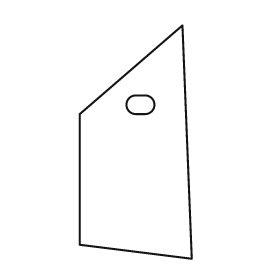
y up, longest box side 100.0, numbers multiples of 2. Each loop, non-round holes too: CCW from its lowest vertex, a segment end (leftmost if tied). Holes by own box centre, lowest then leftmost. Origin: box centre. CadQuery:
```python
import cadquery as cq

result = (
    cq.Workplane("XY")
    .moveTo(24.0, -50.0)
    .lineTo(20.0, 50.0)
    .lineTo(-24.0, 12.0)
    .lineTo(-24.0, -44.0)
    .close()
    .moveTo(0.0, 12.0)
    .lineTo(4.0, 12.0)
    .threePointArc((8.0, 16.0), (4.0, 20.0))
    .lineTo(0.0, 20.0)
    .threePointArc((-4.0, 16.0), (0.0, 12.0))
    .close()
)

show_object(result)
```